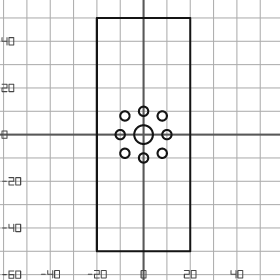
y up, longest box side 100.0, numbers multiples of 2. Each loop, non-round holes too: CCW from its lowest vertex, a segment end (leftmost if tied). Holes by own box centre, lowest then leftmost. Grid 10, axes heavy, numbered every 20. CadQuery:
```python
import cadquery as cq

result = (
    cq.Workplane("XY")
    .moveTo(-20.0, -50.0)
    .lineTo(20.0, -50.0)
    .lineTo(20.0, 50.0)
    .lineTo(-20.0, 50.0)
    .close()
    .moveTo(0.0, -10.0)
    .circle(2.0)
    .moveTo(-8.0, -8.0)
    .circle(2.0)
    .moveTo(8.0, -8.0)
    .circle(2.0)
    .moveTo(-10.0, 0.0)
    .circle(2.0)
    .moveTo(0.0, 0.0)
    .circle(4.0)
    .moveTo(10.0, 0.0)
    .circle(2.0)
    .moveTo(-8.0, 8.0)
    .circle(2.0)
    .moveTo(8.0, 8.0)
    .circle(2.0)
    .moveTo(0.0, 10.0)
    .circle(2.0)
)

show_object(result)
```